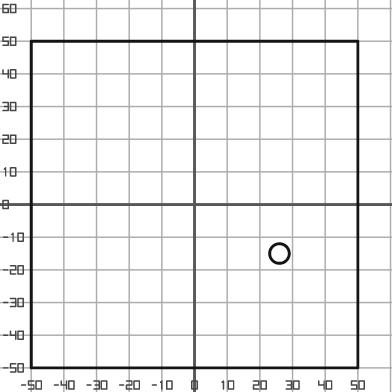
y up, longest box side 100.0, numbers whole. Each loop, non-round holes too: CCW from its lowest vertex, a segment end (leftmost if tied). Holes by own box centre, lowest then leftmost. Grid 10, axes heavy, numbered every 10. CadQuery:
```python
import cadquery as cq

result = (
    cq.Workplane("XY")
    .moveTo(-50.0, -50.0)
    .lineTo(50.0, -50.0)
    .lineTo(50.0, 50.0)
    .lineTo(-50.0, 50.0)
    .close()
    .moveTo(26.0, -15.0)
    .circle(3.0)
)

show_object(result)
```